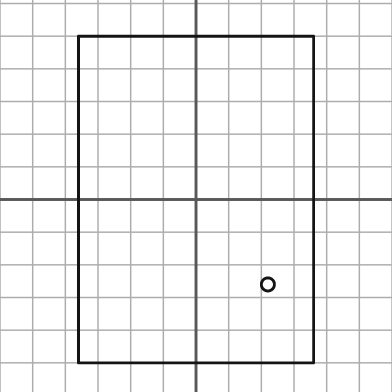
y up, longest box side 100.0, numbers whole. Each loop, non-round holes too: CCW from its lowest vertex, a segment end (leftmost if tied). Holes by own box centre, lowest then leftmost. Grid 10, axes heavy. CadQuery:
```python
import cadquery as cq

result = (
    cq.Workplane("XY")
    .moveTo(-36.0, -50.0)
    .lineTo(36.0, -50.0)
    .lineTo(36.0, 50.0)
    .lineTo(-36.0, 50.0)
    .close()
    .moveTo(22.0, -26.0)
    .circle(2.0)
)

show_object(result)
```